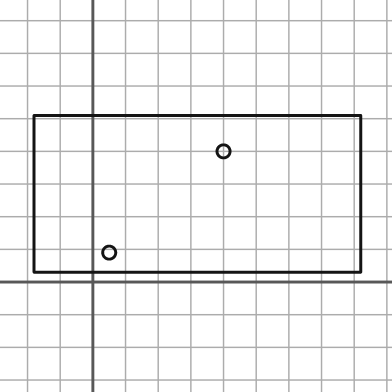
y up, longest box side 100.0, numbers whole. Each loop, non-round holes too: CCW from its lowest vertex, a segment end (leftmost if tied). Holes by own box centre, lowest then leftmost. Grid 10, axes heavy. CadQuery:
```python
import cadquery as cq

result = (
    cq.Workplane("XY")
    .moveTo(-18.0, 3.0)
    .lineTo(82.0, 3.0)
    .lineTo(82.0, 51.0)
    .lineTo(-18.0, 51.0)
    .close()
    .moveTo(5.0, 9.0)
    .circle(2.0)
    .moveTo(40.0, 40.0)
    .circle(2.0)
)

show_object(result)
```